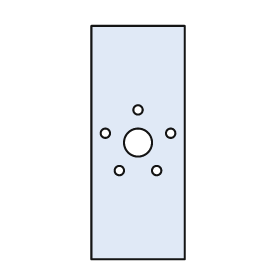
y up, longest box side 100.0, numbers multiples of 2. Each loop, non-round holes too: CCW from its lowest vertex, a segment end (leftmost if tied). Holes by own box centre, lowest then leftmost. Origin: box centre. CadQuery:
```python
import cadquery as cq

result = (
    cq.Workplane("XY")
    .moveTo(-20.0, -50.0)
    .lineTo(20.0, -50.0)
    .lineTo(20.0, 50.0)
    .lineTo(-20.0, 50.0)
    .close()
    .moveTo(-8.0, -12.0)
    .circle(2.0)
    .moveTo(8.0, -12.0)
    .circle(2.0)
    .moveTo(0.0, 0.0)
    .circle(6.0)
    .moveTo(-14.0, 4.0)
    .circle(2.0)
    .moveTo(14.0, 4.0)
    .circle(2.0)
    .moveTo(0.0, 14.0)
    .circle(2.0)
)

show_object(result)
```